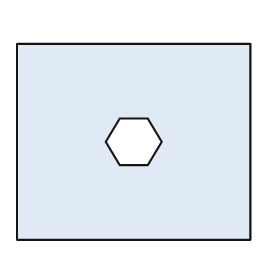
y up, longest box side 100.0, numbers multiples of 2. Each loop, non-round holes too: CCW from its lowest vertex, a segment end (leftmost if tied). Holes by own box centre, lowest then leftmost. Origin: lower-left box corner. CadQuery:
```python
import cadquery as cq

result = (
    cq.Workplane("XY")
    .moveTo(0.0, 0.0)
    .lineTo(100.0, 0.0)
    .lineTo(100.0, 84.0)
    .lineTo(0.0, 84.0)
    .close()
    .moveTo(44.0, 32.0)
    .lineTo(56.0, 32.0)
    .lineTo(62.0, 42.0)
    .lineTo(56.0, 52.0)
    .lineTo(44.0, 52.0)
    .lineTo(38.0, 42.0)
    .close()
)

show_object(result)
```